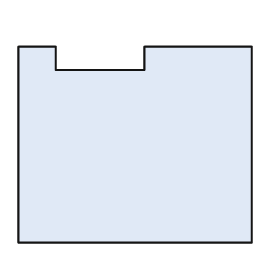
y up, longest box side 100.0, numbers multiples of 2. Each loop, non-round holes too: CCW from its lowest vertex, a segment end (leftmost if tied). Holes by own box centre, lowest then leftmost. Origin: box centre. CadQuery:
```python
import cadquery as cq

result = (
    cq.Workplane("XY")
    .moveTo(-50.0, -42.0)
    .lineTo(50.0, -42.0)
    .lineTo(50.0, 42.0)
    .lineTo(4.0, 42.0)
    .lineTo(4.0, 32.0)
    .lineTo(-34.0, 32.0)
    .lineTo(-34.0, 42.0)
    .lineTo(-50.0, 42.0)
    .close()
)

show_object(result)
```